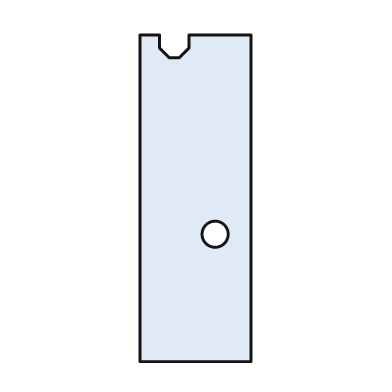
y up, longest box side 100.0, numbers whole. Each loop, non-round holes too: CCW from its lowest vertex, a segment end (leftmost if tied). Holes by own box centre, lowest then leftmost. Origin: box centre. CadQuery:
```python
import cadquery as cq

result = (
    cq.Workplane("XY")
    .moveTo(-17.0, -50.0)
    .lineTo(17.0, -50.0)
    .lineTo(17.0, 50.0)
    .lineTo(-2.0, 50.0)
    .lineTo(-2.0, 46.0)
    .lineTo(-5.0, 43.0)
    .lineTo(-8.0, 43.0)
    .lineTo(-11.0, 46.0)
    .lineTo(-11.0, 50.0)
    .lineTo(-17.0, 50.0)
    .close()
    .moveTo(6.0, -11.0)
    .circle(4.0)
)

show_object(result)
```